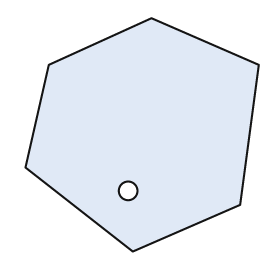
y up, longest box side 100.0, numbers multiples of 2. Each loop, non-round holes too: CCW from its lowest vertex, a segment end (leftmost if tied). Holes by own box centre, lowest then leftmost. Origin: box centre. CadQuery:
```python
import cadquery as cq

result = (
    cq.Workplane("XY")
    .moveTo(-4.0, -50.0)
    .lineTo(42.0, -30.0)
    .lineTo(50.0, 30.0)
    .lineTo(4.0, 50.0)
    .lineTo(-40.0, 30.0)
    .lineTo(-50.0, -14.0)
    .close()
    .moveTo(-6.0, -24.0)
    .circle(4.0)
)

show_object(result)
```